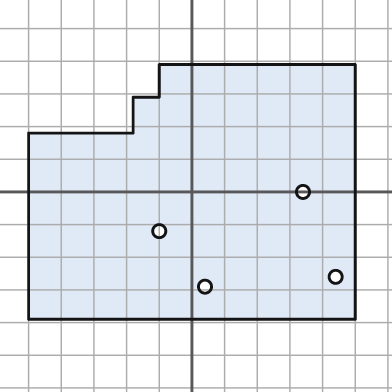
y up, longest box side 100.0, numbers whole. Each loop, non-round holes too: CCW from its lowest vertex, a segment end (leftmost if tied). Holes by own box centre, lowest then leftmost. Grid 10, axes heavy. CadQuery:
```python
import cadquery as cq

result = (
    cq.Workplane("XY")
    .moveTo(-50.0, -39.0)
    .lineTo(50.0, -39.0)
    .lineTo(50.0, 39.0)
    .lineTo(-10.0, 39.0)
    .lineTo(-10.0, 29.0)
    .lineTo(-18.0, 29.0)
    .lineTo(-18.0, 18.0)
    .lineTo(-50.0, 18.0)
    .close()
    .moveTo(4.0, -29.0)
    .circle(2.0)
    .moveTo(44.0, -26.0)
    .circle(2.0)
    .moveTo(-10.0, -12.0)
    .circle(2.0)
    .moveTo(34.0, 0.0)
    .circle(2.0)
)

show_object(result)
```